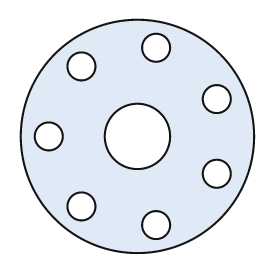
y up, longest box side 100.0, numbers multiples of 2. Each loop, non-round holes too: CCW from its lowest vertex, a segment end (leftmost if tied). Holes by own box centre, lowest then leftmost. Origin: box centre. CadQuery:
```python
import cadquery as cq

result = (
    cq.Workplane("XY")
    .moveTo(0.0, 0.0)
    .circle(50.0)
    .moveTo(8.0, -38.0)
    .circle(6.0)
    .moveTo(-24.0, -30.0)
    .circle(6.0)
    .moveTo(34.0, -16.0)
    .circle(6.0)
    .moveTo(-38.0, 0.0)
    .circle(6.0)
    .moveTo(0.0, 0.0)
    .circle(14.0)
    .moveTo(34.0, 16.0)
    .circle(6.0)
    .moveTo(-24.0, 30.0)
    .circle(6.0)
    .moveTo(8.0, 38.0)
    .circle(6.0)
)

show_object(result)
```